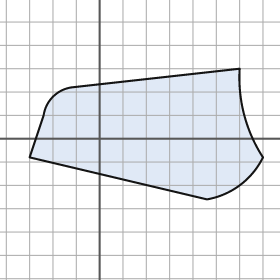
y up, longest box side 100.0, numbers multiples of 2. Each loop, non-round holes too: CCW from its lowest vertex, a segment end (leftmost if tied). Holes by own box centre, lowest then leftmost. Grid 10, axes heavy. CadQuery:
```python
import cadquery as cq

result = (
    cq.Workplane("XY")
    .moveTo(46.0, -26.0)
    .threePointArc((60.0, -20.0), (70.0, -8.0))
    .threePointArc((62.0, 10.0), (60.0, 30.0))
    .lineTo(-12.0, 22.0)
    .threePointArc((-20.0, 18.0), (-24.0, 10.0))
    .lineTo(-30.0, -8.0)
    .close()
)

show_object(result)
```